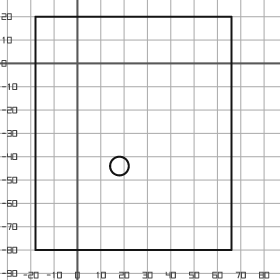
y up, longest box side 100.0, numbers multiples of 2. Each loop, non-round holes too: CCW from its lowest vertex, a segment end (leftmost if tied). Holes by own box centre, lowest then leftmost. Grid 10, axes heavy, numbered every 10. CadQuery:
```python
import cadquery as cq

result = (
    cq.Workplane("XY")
    .moveTo(-18.0, -80.0)
    .lineTo(66.0, -80.0)
    .lineTo(66.0, 20.0)
    .lineTo(-18.0, 20.0)
    .close()
    .moveTo(18.0, -44.0)
    .circle(4.0)
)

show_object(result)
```